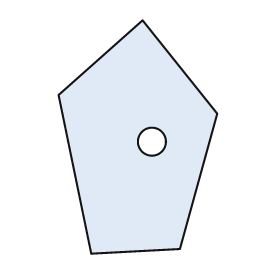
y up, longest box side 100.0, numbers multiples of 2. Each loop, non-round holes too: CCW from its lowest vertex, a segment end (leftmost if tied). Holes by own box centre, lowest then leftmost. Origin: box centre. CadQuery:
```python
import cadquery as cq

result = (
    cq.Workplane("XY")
    .moveTo(-20.0, -50.0)
    .lineTo(18.0, -48.0)
    .lineTo(34.0, 10.0)
    .lineTo(2.0, 50.0)
    .lineTo(-34.0, 18.0)
    .close()
    .moveTo(6.0, -2.0)
    .circle(6.0)
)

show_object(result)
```